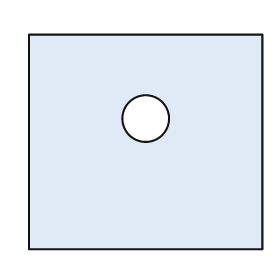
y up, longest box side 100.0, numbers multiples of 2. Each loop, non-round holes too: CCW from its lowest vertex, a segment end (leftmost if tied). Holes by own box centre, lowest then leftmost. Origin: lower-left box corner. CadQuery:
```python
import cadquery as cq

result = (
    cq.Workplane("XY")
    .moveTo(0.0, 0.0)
    .lineTo(100.0, 0.0)
    .lineTo(100.0, 92.0)
    .lineTo(0.0, 92.0)
    .close()
    .moveTo(50.0, 56.0)
    .circle(10.0)
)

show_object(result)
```